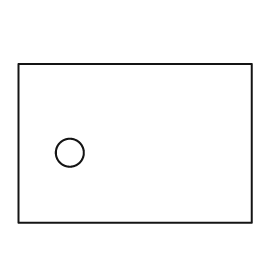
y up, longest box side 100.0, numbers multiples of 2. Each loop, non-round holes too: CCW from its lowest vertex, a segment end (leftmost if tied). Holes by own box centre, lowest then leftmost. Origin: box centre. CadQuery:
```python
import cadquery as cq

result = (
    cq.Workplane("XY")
    .moveTo(-50.0, -34.0)
    .lineTo(50.0, -34.0)
    .lineTo(50.0, 34.0)
    .lineTo(-50.0, 34.0)
    .close()
    .moveTo(-28.0, -4.0)
    .circle(6.0)
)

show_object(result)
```